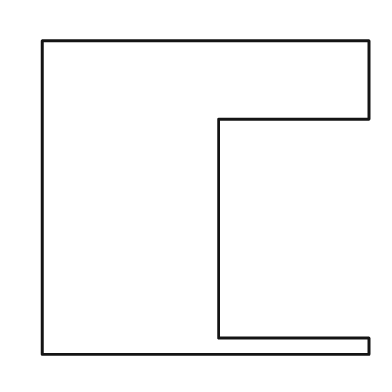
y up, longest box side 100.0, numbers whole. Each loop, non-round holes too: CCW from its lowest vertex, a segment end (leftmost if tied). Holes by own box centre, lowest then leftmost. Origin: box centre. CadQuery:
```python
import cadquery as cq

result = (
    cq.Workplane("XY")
    .moveTo(-50.0, -48.0)
    .lineTo(50.0, -48.0)
    .lineTo(50.0, -43.0)
    .lineTo(4.0, -43.0)
    .lineTo(4.0, 24.0)
    .lineTo(50.0, 24.0)
    .lineTo(50.0, 48.0)
    .lineTo(-50.0, 48.0)
    .close()
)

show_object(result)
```